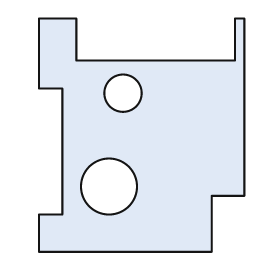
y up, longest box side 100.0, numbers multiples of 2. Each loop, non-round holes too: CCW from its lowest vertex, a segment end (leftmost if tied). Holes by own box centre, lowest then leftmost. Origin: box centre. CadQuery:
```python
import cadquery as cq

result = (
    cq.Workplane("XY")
    .moveTo(-44.0, -50.0)
    .lineTo(30.0, -50.0)
    .lineTo(30.0, -26.0)
    .lineTo(44.0, -26.0)
    .lineTo(44.0, 50.0)
    .lineTo(40.0, 50.0)
    .lineTo(40.0, 32.0)
    .lineTo(-28.0, 32.0)
    .lineTo(-28.0, 50.0)
    .lineTo(-44.0, 50.0)
    .lineTo(-44.0, 20.0)
    .lineTo(-34.0, 20.0)
    .lineTo(-34.0, -34.0)
    .lineTo(-44.0, -34.0)
    .close()
    .moveTo(-14.0, -22.0)
    .circle(12.0)
    .moveTo(-8.0, 18.0)
    .circle(8.0)
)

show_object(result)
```